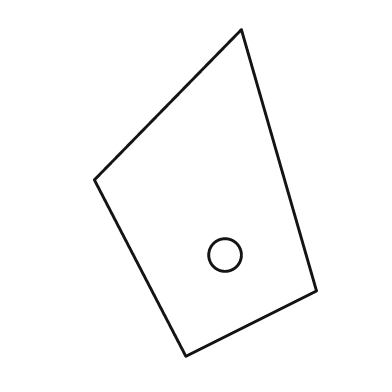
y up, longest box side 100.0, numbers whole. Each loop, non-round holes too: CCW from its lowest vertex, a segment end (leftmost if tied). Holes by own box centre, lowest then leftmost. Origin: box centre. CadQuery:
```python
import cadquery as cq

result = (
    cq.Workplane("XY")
    .moveTo(-6.0, -50.0)
    .lineTo(34.0, -30.0)
    .lineTo(11.0, 50.0)
    .lineTo(-34.0, 4.0)
    .close()
    .moveTo(6.0, -19.0)
    .circle(5.0)
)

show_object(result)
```